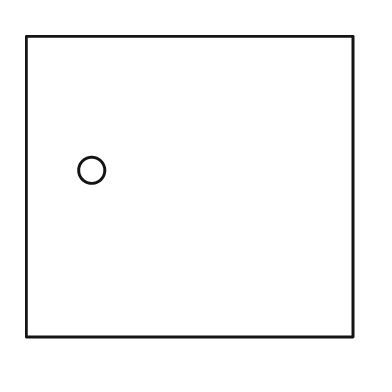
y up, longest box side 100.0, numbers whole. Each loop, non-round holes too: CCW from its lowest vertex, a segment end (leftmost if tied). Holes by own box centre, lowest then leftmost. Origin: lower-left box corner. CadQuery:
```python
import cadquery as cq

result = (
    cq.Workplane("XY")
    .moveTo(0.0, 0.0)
    .lineTo(100.0, 0.0)
    .lineTo(100.0, 92.0)
    .lineTo(0.0, 92.0)
    .close()
    .moveTo(20.0, 51.0)
    .circle(4.0)
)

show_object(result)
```